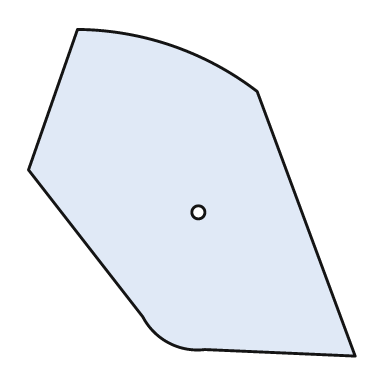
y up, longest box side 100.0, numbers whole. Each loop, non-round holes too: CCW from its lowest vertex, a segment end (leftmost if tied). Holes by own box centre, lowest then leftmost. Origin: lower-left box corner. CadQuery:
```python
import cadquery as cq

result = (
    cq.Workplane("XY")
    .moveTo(100.0, 0.0)
    .lineTo(70.0, 81.0)
    .threePointArc((44.0, 95.0), (15.0, 100.0))
    .lineTo(0.0, 57.0)
    .lineTo(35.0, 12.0)
    .threePointArc((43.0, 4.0), (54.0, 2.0))
    .close()
    .moveTo(52.0, 44.0)
    .circle(2.0)
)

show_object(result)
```